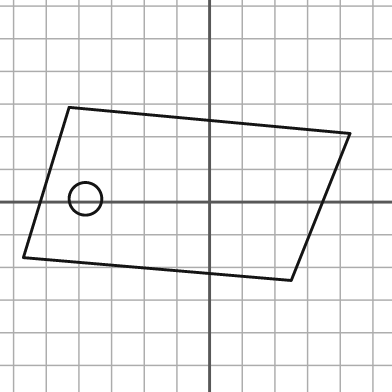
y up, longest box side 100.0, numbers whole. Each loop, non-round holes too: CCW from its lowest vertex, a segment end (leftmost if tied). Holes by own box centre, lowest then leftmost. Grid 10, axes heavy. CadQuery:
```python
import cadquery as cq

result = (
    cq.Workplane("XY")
    .moveTo(25.0, -24.0)
    .lineTo(43.0, 21.0)
    .lineTo(-43.0, 29.0)
    .lineTo(-57.0, -17.0)
    .close()
    .moveTo(-38.0, 1.0)
    .circle(5.0)
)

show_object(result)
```